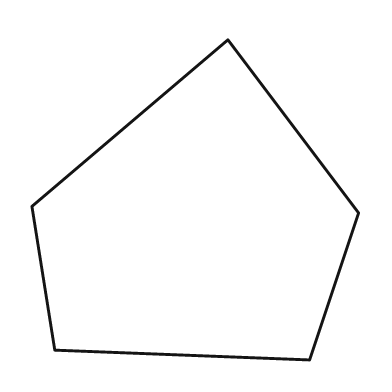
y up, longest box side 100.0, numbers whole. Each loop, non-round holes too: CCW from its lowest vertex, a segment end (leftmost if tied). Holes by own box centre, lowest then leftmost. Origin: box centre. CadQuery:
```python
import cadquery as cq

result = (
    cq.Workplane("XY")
    .moveTo(35.0, -49.0)
    .lineTo(50.0, -4.0)
    .lineTo(10.0, 49.0)
    .lineTo(-50.0, -2.0)
    .lineTo(-43.0, -46.0)
    .close()
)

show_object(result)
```